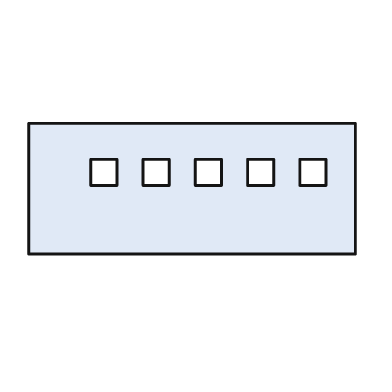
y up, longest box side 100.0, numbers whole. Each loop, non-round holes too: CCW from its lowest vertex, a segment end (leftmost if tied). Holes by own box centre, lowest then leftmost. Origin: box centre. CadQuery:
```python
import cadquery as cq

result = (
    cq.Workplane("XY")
    .moveTo(-50.0, -20.0)
    .lineTo(50.0, -20.0)
    .lineTo(50.0, 20.0)
    .lineTo(-50.0, 20.0)
    .close()
    .moveTo(-31.0, 1.0)
    .lineTo(-23.0, 1.0)
    .lineTo(-23.0, 9.0)
    .lineTo(-31.0, 9.0)
    .close()
    .moveTo(-15.0, 1.0)
    .lineTo(-7.0, 1.0)
    .lineTo(-7.0, 9.0)
    .lineTo(-15.0, 9.0)
    .close()
    .moveTo(1.0, 1.0)
    .lineTo(9.0, 1.0)
    .lineTo(9.0, 9.0)
    .lineTo(1.0, 9.0)
    .close()
    .moveTo(17.0, 1.0)
    .lineTo(25.0, 1.0)
    .lineTo(25.0, 9.0)
    .lineTo(17.0, 9.0)
    .close()
    .moveTo(33.0, 1.0)
    .lineTo(41.0, 1.0)
    .lineTo(41.0, 9.0)
    .lineTo(33.0, 9.0)
    .close()
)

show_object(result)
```